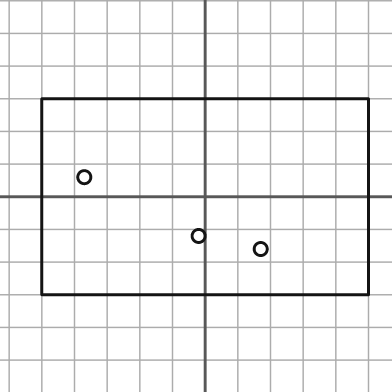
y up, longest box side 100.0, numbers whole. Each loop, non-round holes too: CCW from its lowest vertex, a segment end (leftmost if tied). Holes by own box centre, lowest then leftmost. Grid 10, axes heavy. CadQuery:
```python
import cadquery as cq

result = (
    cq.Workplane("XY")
    .moveTo(-50.0, -30.0)
    .lineTo(50.0, -30.0)
    .lineTo(50.0, 30.0)
    .lineTo(-50.0, 30.0)
    .close()
    .moveTo(17.0, -16.0)
    .circle(2.0)
    .moveTo(-2.0, -12.0)
    .circle(2.0)
    .moveTo(-37.0, 6.0)
    .circle(2.0)
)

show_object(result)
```